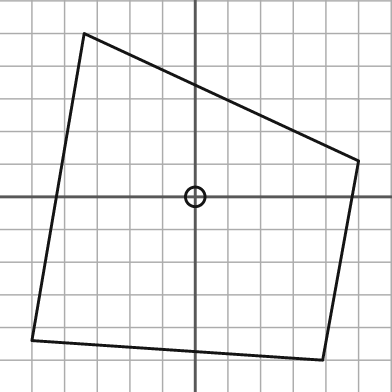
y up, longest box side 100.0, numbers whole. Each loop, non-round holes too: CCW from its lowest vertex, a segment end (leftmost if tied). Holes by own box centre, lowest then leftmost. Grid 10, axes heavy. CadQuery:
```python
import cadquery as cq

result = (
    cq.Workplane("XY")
    .moveTo(39.0, -50.0)
    .lineTo(50.0, 11.0)
    .lineTo(-34.0, 50.0)
    .lineTo(-50.0, -44.0)
    .close()
    .moveTo(0.0, 0.0)
    .circle(3.0)
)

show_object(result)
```